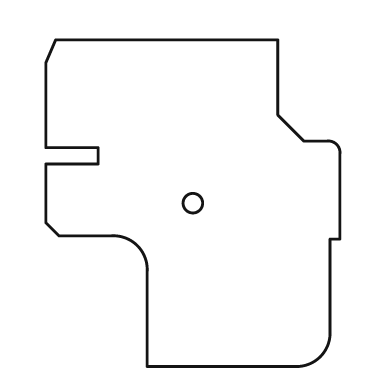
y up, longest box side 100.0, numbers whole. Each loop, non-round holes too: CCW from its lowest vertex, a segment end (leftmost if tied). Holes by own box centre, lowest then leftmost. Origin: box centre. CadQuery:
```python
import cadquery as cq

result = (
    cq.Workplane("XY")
    .moveTo(-14.0, -50.0)
    .lineTo(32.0, -50.0)
    .threePointArc((39.0, -47.0), (42.0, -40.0))
    .lineTo(42.0, -11.0)
    .lineTo(45.0, -11.0)
    .lineTo(45.0, 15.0)
    .threePointArc((44.0, 18.0), (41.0, 19.0))
    .lineTo(34.0, 19.0)
    .lineTo(26.0, 27.0)
    .lineTo(26.0, 50.0)
    .lineTo(-42.0, 50.0)
    .lineTo(-45.0, 43.0)
    .lineTo(-45.0, 17.0)
    .lineTo(-29.0, 17.0)
    .lineTo(-29.0, 12.0)
    .lineTo(-45.0, 12.0)
    .lineTo(-45.0, -6.0)
    .lineTo(-41.0, -10.0)
    .lineTo(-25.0, -10.0)
    .threePointArc((-17.0, -13.0), (-14.0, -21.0))
    .close()
    .moveTo(0.0, 0.0)
    .circle(3.0)
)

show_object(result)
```